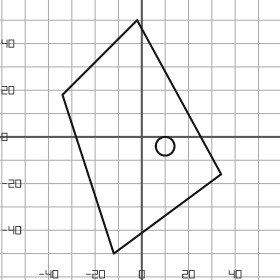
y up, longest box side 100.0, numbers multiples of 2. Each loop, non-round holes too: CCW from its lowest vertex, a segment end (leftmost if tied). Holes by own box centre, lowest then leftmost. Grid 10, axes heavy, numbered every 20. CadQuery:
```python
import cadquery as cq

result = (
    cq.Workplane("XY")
    .moveTo(-12.0, -50.0)
    .lineTo(34.0, -16.0)
    .lineTo(-2.0, 50.0)
    .lineTo(-34.0, 18.0)
    .close()
    .moveTo(10.0, -4.0)
    .circle(4.0)
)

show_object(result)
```